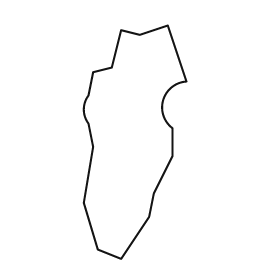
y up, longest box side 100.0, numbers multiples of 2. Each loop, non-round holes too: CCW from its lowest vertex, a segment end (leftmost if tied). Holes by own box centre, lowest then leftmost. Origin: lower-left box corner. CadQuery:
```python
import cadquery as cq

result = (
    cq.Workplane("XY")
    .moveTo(16.0, 0.0)
    .lineTo(28.0, 18.0)
    .lineTo(30.0, 28.0)
    .lineTo(38.0, 44.0)
    .lineTo(38.0, 56.0)
    .threePointArc((34.0, 68.0), (44.0, 76.0))
    .lineTo(36.0, 100.0)
    .lineTo(24.0, 96.0)
    .lineTo(16.0, 98.0)
    .lineTo(12.0, 82.0)
    .lineTo(4.0, 80.0)
    .lineTo(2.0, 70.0)
    .threePointArc((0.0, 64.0), (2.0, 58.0))
    .lineTo(4.0, 48.0)
    .lineTo(0.0, 24.0)
    .lineTo(6.0, 4.0)
    .close()
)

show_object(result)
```